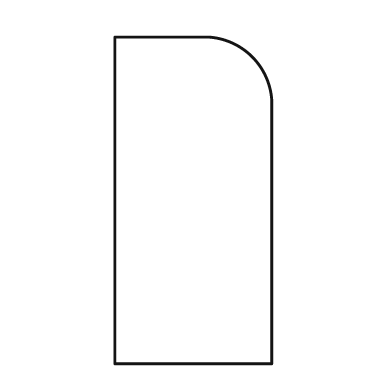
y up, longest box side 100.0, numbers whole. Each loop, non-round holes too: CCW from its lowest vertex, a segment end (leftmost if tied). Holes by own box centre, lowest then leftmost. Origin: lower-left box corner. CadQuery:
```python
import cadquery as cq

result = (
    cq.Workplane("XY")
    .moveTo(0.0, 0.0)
    .lineTo(48.0, 0.0)
    .lineTo(48.0, 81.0)
    .threePointArc((42.0, 94.0), (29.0, 100.0))
    .lineTo(0.0, 100.0)
    .close()
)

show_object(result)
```